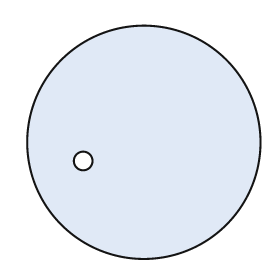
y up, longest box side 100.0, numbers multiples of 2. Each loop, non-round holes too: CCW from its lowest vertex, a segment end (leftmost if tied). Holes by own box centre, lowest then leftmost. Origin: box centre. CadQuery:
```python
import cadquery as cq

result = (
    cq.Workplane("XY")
    .moveTo(0.0, 0.0)
    .circle(50.0)
    .moveTo(-26.0, -8.0)
    .circle(4.0)
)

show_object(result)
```